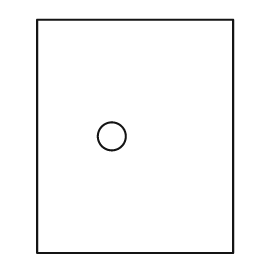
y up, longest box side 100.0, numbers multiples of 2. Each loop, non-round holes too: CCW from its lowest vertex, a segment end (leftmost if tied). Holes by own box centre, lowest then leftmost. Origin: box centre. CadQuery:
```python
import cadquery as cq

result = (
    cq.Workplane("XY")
    .moveTo(-42.0, -50.0)
    .lineTo(42.0, -50.0)
    .lineTo(42.0, 50.0)
    .lineTo(-42.0, 50.0)
    .close()
    .moveTo(-10.0, 0.0)
    .circle(6.0)
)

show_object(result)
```